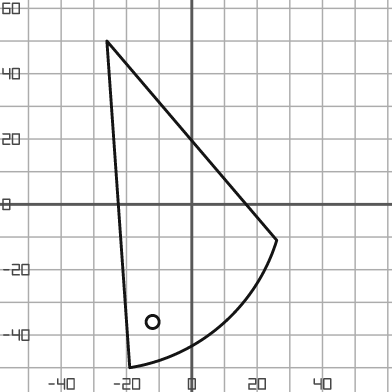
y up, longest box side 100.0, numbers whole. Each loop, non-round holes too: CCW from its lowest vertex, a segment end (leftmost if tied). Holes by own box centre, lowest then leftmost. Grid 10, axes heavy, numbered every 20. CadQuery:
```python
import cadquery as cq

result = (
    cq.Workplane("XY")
    .moveTo(-19.0, -50.0)
    .threePointArc((9.0, -37.0), (26.0, -11.0))
    .lineTo(-26.0, 50.0)
    .close()
    .moveTo(-12.0, -36.0)
    .circle(2.0)
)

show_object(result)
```